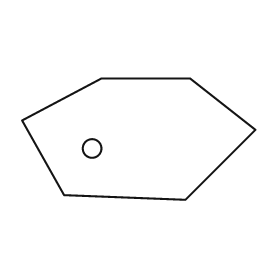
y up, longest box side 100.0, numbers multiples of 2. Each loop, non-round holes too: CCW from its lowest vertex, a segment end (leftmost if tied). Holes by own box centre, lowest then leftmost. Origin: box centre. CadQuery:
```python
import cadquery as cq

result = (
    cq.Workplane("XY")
    .moveTo(20.0, -26.0)
    .lineTo(50.0, 4.0)
    .lineTo(22.0, 26.0)
    .lineTo(-16.0, 26.0)
    .lineTo(-50.0, 8.0)
    .lineTo(-32.0, -24.0)
    .close()
    .moveTo(-20.0, -4.0)
    .circle(4.0)
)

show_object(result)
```